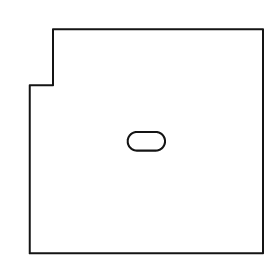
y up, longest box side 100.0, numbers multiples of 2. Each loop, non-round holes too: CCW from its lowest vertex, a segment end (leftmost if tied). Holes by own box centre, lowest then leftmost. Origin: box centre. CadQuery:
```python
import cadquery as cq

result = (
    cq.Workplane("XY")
    .moveTo(-50.0, -48.0)
    .lineTo(50.0, -48.0)
    .lineTo(50.0, 48.0)
    .lineTo(-40.0, 48.0)
    .lineTo(-40.0, 24.0)
    .lineTo(-50.0, 24.0)
    .close()
    .moveTo(-4.0, -4.0)
    .lineTo(4.0, -4.0)
    .threePointArc((8.0, 0.0), (4.0, 4.0))
    .lineTo(-4.0, 4.0)
    .threePointArc((-8.0, 0.0), (-4.0, -4.0))
    .close()
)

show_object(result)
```